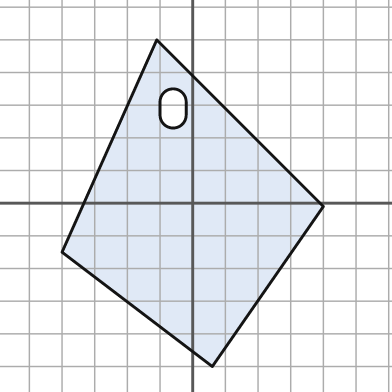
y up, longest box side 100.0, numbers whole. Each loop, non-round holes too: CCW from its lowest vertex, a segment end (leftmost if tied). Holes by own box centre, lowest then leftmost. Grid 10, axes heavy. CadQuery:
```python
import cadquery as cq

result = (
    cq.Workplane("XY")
    .moveTo(6.0, -50.0)
    .lineTo(40.0, -1.0)
    .lineTo(-11.0, 50.0)
    .lineTo(-40.0, -15.0)
    .close()
    .moveTo(-10.0, 27.0)
    .threePointArc((-6.0, 23.0), (-2.0, 27.0))
    .lineTo(-2.0, 31.0)
    .threePointArc((-6.0, 35.0), (-10.0, 31.0))
    .close()
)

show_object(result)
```